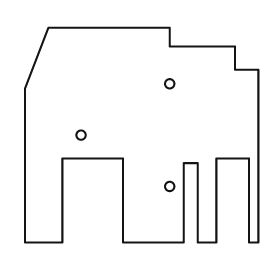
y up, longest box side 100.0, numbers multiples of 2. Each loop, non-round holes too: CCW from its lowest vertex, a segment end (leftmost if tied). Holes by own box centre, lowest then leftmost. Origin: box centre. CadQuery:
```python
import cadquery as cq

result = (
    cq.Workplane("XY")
    .moveTo(-50.0, -46.0)
    .lineTo(-34.0, -46.0)
    .lineTo(-34.0, -10.0)
    .lineTo(-8.0, -10.0)
    .lineTo(-8.0, -46.0)
    .lineTo(18.0, -46.0)
    .lineTo(18.0, -12.0)
    .lineTo(24.0, -12.0)
    .lineTo(24.0, -46.0)
    .lineTo(32.0, -46.0)
    .lineTo(32.0, -10.0)
    .lineTo(46.0, -10.0)
    .lineTo(46.0, -46.0)
    .lineTo(50.0, -46.0)
    .lineTo(50.0, 28.0)
    .lineTo(40.0, 28.0)
    .lineTo(40.0, 38.0)
    .lineTo(12.0, 38.0)
    .lineTo(12.0, 46.0)
    .lineTo(-40.0, 46.0)
    .lineTo(-50.0, 20.0)
    .close()
    .moveTo(12.0, -22.0)
    .circle(2.0)
    .moveTo(-26.0, 0.0)
    .circle(2.0)
    .moveTo(12.0, 22.0)
    .circle(2.0)
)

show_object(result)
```